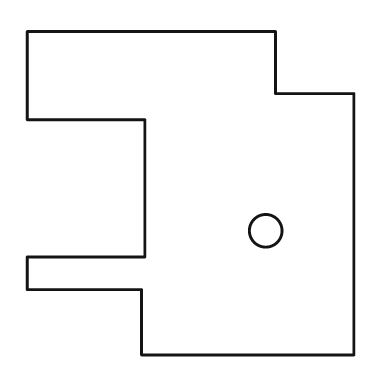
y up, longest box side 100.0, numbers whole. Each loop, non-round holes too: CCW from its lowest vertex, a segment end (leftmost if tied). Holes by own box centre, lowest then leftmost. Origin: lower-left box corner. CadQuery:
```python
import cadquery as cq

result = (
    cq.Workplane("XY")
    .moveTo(35.0, 0.0)
    .lineTo(100.0, 0.0)
    .lineTo(100.0, 80.0)
    .lineTo(76.0, 80.0)
    .lineTo(76.0, 99.0)
    .lineTo(0.0, 99.0)
    .lineTo(0.0, 72.0)
    .lineTo(36.0, 72.0)
    .lineTo(36.0, 30.0)
    .lineTo(0.0, 30.0)
    .lineTo(0.0, 20.0)
    .lineTo(35.0, 20.0)
    .close()
    .moveTo(73.0, 38.0)
    .circle(5.0)
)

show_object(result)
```